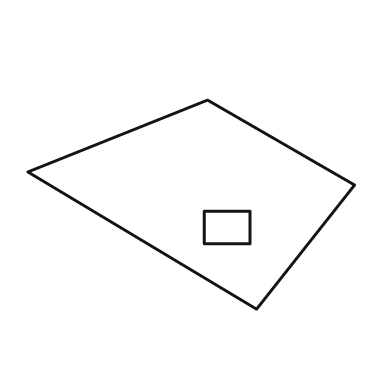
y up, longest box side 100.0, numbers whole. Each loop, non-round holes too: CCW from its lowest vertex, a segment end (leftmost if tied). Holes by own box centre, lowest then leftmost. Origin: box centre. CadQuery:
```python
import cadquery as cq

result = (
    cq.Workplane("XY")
    .moveTo(20.0, -32.0)
    .lineTo(50.0, 6.0)
    .lineTo(5.0, 32.0)
    .lineTo(-50.0, 10.0)
    .close()
    .moveTo(4.0, -12.0)
    .lineTo(18.0, -12.0)
    .lineTo(18.0, -2.0)
    .lineTo(4.0, -2.0)
    .close()
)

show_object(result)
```